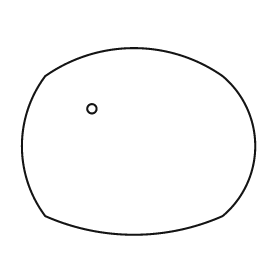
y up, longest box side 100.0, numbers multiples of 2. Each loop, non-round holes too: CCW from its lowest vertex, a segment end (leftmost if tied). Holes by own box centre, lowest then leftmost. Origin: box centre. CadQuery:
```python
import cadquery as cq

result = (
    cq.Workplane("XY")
    .moveTo(-40.0, -32.0)
    .threePointArc((-2.0, -40.0), (36.0, -32.0))
    .threePointArc((50.0, -2.0), (36.0, 28.0))
    .threePointArc((-2.0, 40.0), (-40.0, 28.0))
    .threePointArc((-50.0, -2.0), (-40.0, -32.0))
    .close()
    .moveTo(-20.0, 14.0)
    .circle(2.0)
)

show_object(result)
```